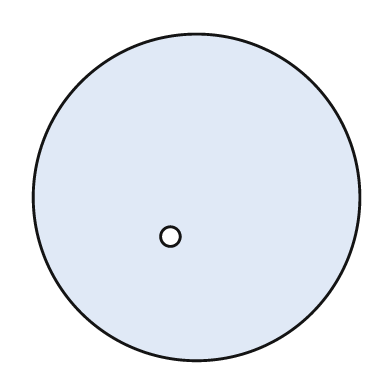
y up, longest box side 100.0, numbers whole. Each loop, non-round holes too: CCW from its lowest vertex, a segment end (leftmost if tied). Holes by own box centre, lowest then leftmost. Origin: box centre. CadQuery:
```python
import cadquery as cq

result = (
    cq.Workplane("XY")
    .moveTo(0.0, 0.0)
    .circle(50.0)
    .moveTo(-8.0, -12.0)
    .circle(3.0)
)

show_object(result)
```